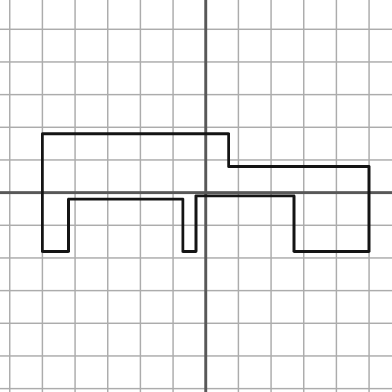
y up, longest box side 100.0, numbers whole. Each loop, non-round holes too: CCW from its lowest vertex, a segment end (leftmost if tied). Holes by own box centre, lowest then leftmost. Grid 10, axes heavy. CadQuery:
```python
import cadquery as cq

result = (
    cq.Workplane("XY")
    .moveTo(-50.0, -18.0)
    .lineTo(-42.0, -18.0)
    .lineTo(-42.0, -2.0)
    .lineTo(-7.0, -2.0)
    .lineTo(-7.0, -18.0)
    .lineTo(-3.0, -18.0)
    .lineTo(-3.0, -1.0)
    .lineTo(27.0, -1.0)
    .lineTo(27.0, -18.0)
    .lineTo(50.0, -18.0)
    .lineTo(50.0, 8.0)
    .lineTo(7.0, 8.0)
    .lineTo(7.0, 18.0)
    .lineTo(-50.0, 18.0)
    .close()
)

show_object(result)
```